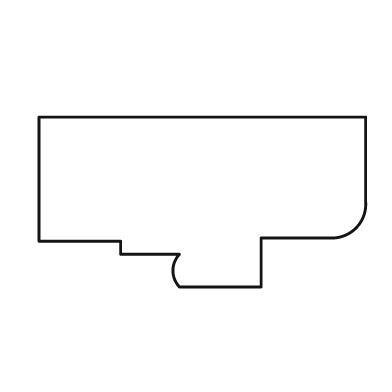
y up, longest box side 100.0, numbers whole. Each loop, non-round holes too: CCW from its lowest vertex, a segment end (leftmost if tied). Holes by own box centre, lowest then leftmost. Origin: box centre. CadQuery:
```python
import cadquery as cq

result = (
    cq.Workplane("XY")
    .moveTo(-7.0, -26.0)
    .lineTo(18.0, -26.0)
    .lineTo(18.0, -11.0)
    .lineTo(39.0, -11.0)
    .threePointArc((47.0, -8.0), (50.0, 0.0))
    .lineTo(50.0, 26.0)
    .lineTo(-50.0, 26.0)
    .lineTo(-50.0, -12.0)
    .lineTo(-25.0, -12.0)
    .lineTo(-25.0, -16.0)
    .lineTo(-7.0, -16.0)
    .threePointArc((-9.0, -21.0), (-7.0, -26.0))
    .close()
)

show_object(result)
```